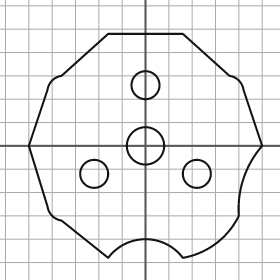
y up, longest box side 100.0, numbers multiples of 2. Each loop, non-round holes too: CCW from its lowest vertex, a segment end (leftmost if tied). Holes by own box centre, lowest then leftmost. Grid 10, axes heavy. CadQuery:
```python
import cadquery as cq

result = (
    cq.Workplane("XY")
    .moveTo(-16.0, -48.0)
    .threePointArc((0.0, -40.0), (16.0, -48.0))
    .threePointArc((30.0, -42.0), (40.0, -30.0))
    .threePointArc((42.0, -14.0), (50.0, 0.0))
    .lineTo(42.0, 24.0)
    .threePointArc((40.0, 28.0), (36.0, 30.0))
    .lineTo(16.0, 48.0)
    .lineTo(-16.0, 48.0)
    .lineTo(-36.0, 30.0)
    .threePointArc((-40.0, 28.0), (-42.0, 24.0))
    .lineTo(-50.0, 0.0)
    .lineTo(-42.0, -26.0)
    .threePointArc((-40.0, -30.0), (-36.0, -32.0))
    .close()
    .moveTo(-22.0, -12.0)
    .circle(6.0)
    .moveTo(22.0, -12.0)
    .circle(6.0)
    .moveTo(0.0, 0.0)
    .circle(8.0)
    .moveTo(0.0, 26.0)
    .circle(6.0)
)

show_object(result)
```